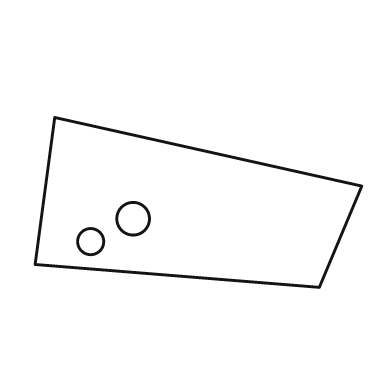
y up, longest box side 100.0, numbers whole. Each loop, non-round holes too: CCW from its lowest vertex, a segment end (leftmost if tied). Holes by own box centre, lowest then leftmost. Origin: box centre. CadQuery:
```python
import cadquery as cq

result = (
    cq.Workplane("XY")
    .moveTo(37.0, -26.0)
    .lineTo(50.0, 5.0)
    .lineTo(-44.0, 26.0)
    .lineTo(-50.0, -19.0)
    .close()
    .moveTo(-33.0, -12.0)
    .circle(4.0)
    .moveTo(-20.0, -5.0)
    .circle(5.0)
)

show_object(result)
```